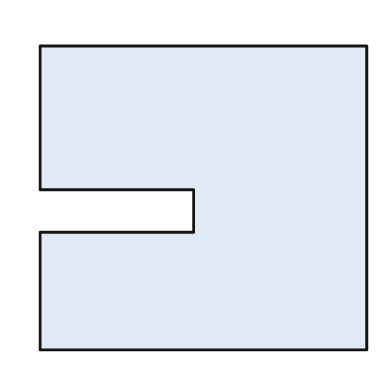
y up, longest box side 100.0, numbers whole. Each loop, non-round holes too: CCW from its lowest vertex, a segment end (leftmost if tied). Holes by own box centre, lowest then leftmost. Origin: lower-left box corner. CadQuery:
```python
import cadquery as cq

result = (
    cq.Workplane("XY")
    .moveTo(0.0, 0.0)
    .lineTo(100.0, 0.0)
    .lineTo(100.0, 93.0)
    .lineTo(0.0, 93.0)
    .lineTo(0.0, 49.0)
    .lineTo(47.0, 49.0)
    .lineTo(47.0, 36.0)
    .lineTo(0.0, 36.0)
    .close()
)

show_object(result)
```